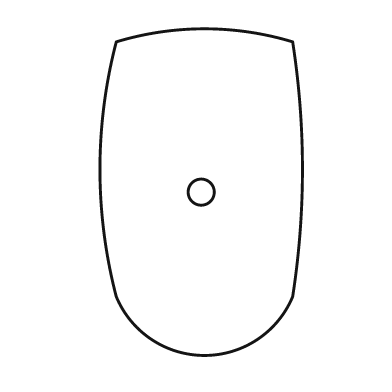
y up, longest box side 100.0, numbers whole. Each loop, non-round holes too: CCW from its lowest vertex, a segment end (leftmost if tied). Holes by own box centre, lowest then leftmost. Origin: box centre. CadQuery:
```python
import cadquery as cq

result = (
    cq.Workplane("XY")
    .moveTo(-26.0, -32.0)
    .threePointArc((1.0, -50.0), (28.0, -32.0))
    .threePointArc((31.0, 7.0), (28.0, 46.0))
    .threePointArc((1.0, 50.0), (-26.0, 46.0))
    .threePointArc((-31.0, 7.0), (-26.0, -32.0))
    .close()
    .moveTo(0.0, 0.0)
    .circle(4.0)
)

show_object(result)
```